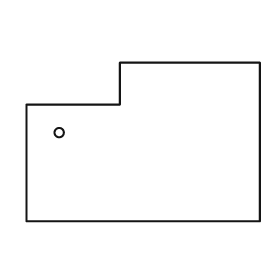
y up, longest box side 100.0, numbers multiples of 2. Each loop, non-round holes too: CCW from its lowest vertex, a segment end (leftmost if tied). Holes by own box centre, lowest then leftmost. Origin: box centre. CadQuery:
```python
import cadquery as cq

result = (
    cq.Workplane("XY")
    .moveTo(-50.0, -34.0)
    .lineTo(50.0, -34.0)
    .lineTo(50.0, 34.0)
    .lineTo(-10.0, 34.0)
    .lineTo(-10.0, 16.0)
    .lineTo(-50.0, 16.0)
    .close()
    .moveTo(-36.0, 4.0)
    .circle(2.0)
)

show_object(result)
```